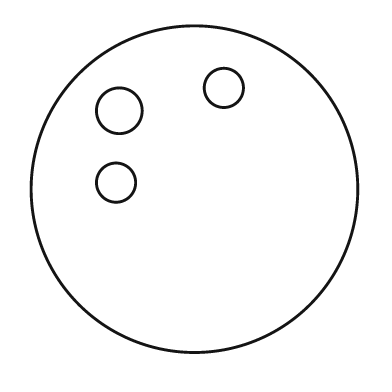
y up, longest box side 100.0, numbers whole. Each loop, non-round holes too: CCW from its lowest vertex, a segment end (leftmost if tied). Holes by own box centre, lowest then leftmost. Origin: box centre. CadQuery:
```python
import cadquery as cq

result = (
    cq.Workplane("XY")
    .moveTo(0.0, 0.0)
    .circle(50.0)
    .moveTo(-24.0, 2.0)
    .circle(6.0)
    .moveTo(-23.0, 24.0)
    .circle(7.0)
    .moveTo(9.0, 31.0)
    .circle(6.0)
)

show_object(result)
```